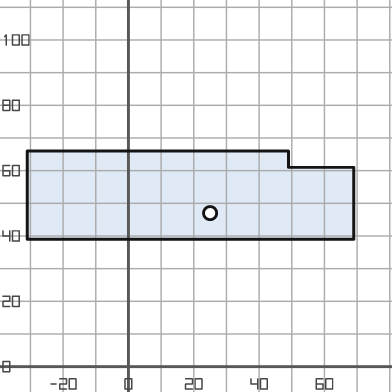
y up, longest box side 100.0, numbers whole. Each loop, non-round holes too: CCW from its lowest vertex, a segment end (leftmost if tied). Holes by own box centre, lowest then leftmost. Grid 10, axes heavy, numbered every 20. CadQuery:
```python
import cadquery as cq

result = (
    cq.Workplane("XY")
    .moveTo(-31.0, 39.0)
    .lineTo(69.0, 39.0)
    .lineTo(69.0, 61.0)
    .lineTo(49.0, 61.0)
    .lineTo(49.0, 66.0)
    .lineTo(-31.0, 66.0)
    .close()
    .moveTo(25.0, 47.0)
    .circle(2.0)
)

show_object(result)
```